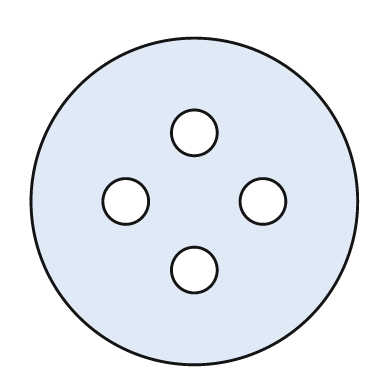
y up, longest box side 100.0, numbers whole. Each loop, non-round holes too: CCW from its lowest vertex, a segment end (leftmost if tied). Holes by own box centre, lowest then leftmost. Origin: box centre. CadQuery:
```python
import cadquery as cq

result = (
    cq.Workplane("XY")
    .moveTo(0.0, 0.0)
    .circle(50.0)
    .moveTo(0.0, -21.0)
    .circle(7.0)
    .moveTo(-21.0, 0.0)
    .circle(7.0)
    .moveTo(21.0, 0.0)
    .circle(7.0)
    .moveTo(0.0, 21.0)
    .circle(7.0)
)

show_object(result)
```